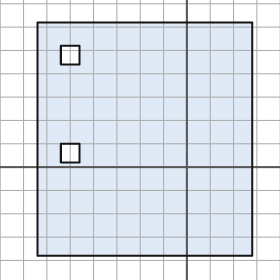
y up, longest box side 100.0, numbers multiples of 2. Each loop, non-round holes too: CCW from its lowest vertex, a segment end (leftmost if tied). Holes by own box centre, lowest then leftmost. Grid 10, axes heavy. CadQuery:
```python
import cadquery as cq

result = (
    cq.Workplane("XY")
    .moveTo(-64.0, -38.0)
    .lineTo(28.0, -38.0)
    .lineTo(28.0, 62.0)
    .lineTo(-64.0, 62.0)
    .close()
    .moveTo(-54.0, 2.0)
    .lineTo(-46.0, 2.0)
    .lineTo(-46.0, 10.0)
    .lineTo(-54.0, 10.0)
    .close()
    .moveTo(-54.0, 44.0)
    .lineTo(-46.0, 44.0)
    .lineTo(-46.0, 52.0)
    .lineTo(-54.0, 52.0)
    .close()
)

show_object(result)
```